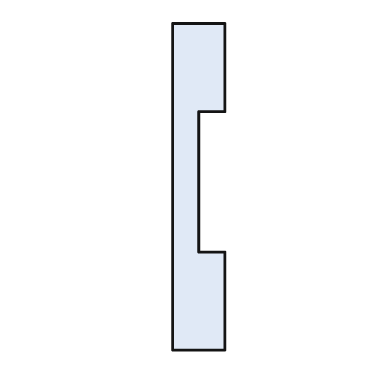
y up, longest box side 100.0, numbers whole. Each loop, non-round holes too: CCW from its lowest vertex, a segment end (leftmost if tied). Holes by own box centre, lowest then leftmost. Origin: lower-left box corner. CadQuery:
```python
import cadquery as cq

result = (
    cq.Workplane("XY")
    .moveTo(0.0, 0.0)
    .lineTo(16.0, 0.0)
    .lineTo(16.0, 30.0)
    .lineTo(8.0, 30.0)
    .lineTo(8.0, 73.0)
    .lineTo(16.0, 73.0)
    .lineTo(16.0, 100.0)
    .lineTo(0.0, 100.0)
    .close()
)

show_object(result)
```